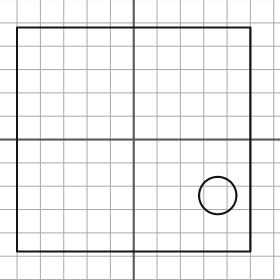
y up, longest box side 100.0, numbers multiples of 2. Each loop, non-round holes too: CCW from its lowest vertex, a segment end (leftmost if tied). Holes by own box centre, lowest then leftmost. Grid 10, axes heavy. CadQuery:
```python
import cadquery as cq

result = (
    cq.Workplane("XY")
    .moveTo(-50.0, -48.0)
    .lineTo(50.0, -48.0)
    .lineTo(50.0, 48.0)
    .lineTo(-50.0, 48.0)
    .close()
    .moveTo(36.0, -24.0)
    .circle(8.0)
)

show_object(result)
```